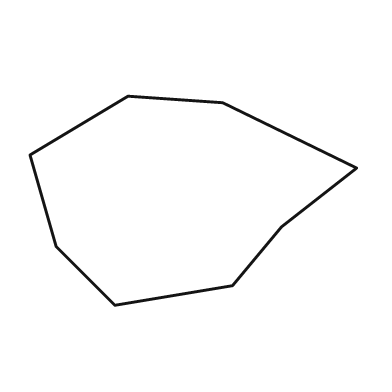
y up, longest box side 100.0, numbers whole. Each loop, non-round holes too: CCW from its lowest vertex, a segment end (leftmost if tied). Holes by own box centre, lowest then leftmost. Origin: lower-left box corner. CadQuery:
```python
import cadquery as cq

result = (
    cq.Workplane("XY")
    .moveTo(26.0, 0.0)
    .lineTo(62.0, 6.0)
    .lineTo(77.0, 24.0)
    .lineTo(100.0, 42.0)
    .lineTo(59.0, 62.0)
    .lineTo(30.0, 64.0)
    .lineTo(0.0, 46.0)
    .lineTo(8.0, 18.0)
    .close()
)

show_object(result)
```